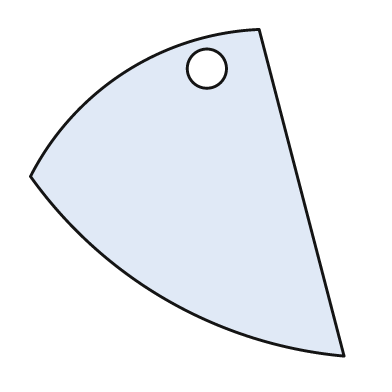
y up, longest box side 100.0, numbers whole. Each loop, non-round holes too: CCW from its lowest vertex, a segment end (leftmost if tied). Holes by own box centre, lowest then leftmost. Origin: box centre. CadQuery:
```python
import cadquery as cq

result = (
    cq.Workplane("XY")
    .moveTo(48.0, -50.0)
    .lineTo(22.0, 50.0)
    .threePointArc((-19.0, 37.0), (-48.0, 5.0))
    .threePointArc((-6.0, -33.0), (48.0, -50.0))
    .close()
    .moveTo(6.0, 38.0)
    .circle(6.0)
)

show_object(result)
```